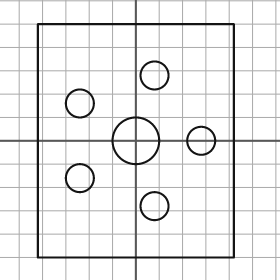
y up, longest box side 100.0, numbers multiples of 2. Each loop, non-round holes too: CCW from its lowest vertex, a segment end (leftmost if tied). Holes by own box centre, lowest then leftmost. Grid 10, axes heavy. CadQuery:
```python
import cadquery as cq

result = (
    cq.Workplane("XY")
    .moveTo(-42.0, -50.0)
    .lineTo(42.0, -50.0)
    .lineTo(42.0, 50.0)
    .lineTo(-42.0, 50.0)
    .close()
    .moveTo(8.0, -28.0)
    .circle(6.0)
    .moveTo(-24.0, -16.0)
    .circle(6.0)
    .moveTo(0.0, 0.0)
    .circle(10.0)
    .moveTo(28.0, 0.0)
    .circle(6.0)
    .moveTo(-24.0, 16.0)
    .circle(6.0)
    .moveTo(8.0, 28.0)
    .circle(6.0)
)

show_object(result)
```